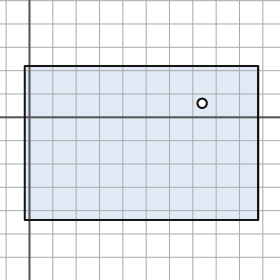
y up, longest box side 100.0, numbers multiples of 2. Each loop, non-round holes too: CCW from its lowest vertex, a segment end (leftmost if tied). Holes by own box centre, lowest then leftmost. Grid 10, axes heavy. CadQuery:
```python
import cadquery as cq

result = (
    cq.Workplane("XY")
    .moveTo(-2.0, -44.0)
    .lineTo(98.0, -44.0)
    .lineTo(98.0, 22.0)
    .lineTo(-2.0, 22.0)
    .close()
    .moveTo(74.0, 6.0)
    .circle(2.0)
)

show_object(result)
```